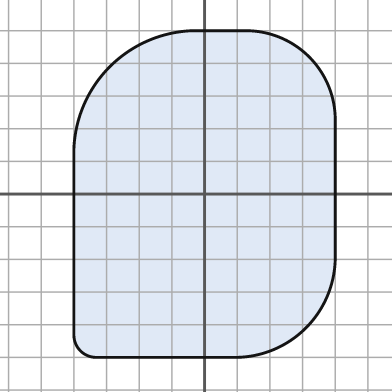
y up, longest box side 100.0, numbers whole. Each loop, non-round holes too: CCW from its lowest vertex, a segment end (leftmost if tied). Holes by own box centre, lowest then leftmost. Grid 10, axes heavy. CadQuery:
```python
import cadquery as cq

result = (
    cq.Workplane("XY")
    .moveTo(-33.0, -50.0)
    .lineTo(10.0, -50.0)
    .threePointArc((31.0, -41.0), (40.0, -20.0))
    .lineTo(40.0, 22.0)
    .threePointArc((32.0, 42.0), (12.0, 50.0))
    .lineTo(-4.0, 50.0)
    .threePointArc((-29.0, 39.0), (-40.0, 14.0))
    .lineTo(-40.0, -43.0)
    .threePointArc((-38.0, -48.0), (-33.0, -50.0))
    .close()
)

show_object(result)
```